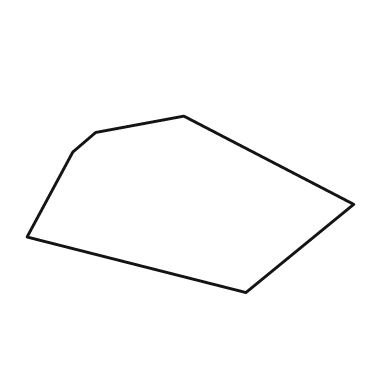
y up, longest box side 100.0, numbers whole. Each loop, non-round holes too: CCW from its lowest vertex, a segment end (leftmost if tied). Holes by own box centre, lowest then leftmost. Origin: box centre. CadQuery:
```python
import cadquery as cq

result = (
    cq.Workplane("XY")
    .moveTo(17.0, -27.0)
    .lineTo(50.0, 0.0)
    .lineTo(-2.0, 27.0)
    .lineTo(-29.0, 22.0)
    .lineTo(-36.0, 16.0)
    .lineTo(-50.0, -10.0)
    .close()
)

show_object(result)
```